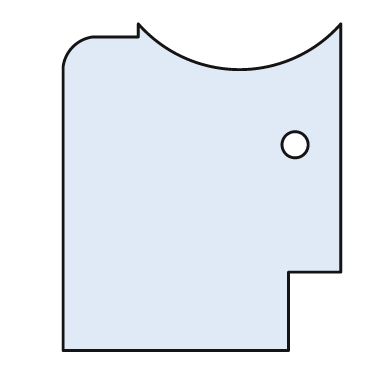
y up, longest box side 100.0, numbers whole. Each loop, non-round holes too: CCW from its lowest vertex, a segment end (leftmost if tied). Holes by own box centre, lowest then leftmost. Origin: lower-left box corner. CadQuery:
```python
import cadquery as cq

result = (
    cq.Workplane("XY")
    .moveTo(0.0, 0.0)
    .lineTo(69.0, 0.0)
    .lineTo(69.0, 24.0)
    .lineTo(85.0, 24.0)
    .lineTo(85.0, 100.0)
    .threePointArc((54.0, 86.0), (23.0, 100.0))
    .lineTo(23.0, 96.0)
    .lineTo(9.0, 96.0)
    .threePointArc((3.0, 93.0), (0.0, 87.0))
    .close()
    .moveTo(71.0, 63.0)
    .circle(4.0)
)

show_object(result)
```